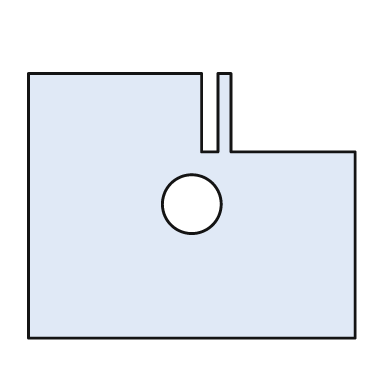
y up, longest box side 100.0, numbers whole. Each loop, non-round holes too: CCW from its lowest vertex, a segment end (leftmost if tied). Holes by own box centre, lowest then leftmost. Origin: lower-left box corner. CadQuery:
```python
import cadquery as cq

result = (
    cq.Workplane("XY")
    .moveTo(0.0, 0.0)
    .lineTo(100.0, 0.0)
    .lineTo(100.0, 57.0)
    .lineTo(62.0, 57.0)
    .lineTo(62.0, 81.0)
    .lineTo(58.0, 81.0)
    .lineTo(58.0, 57.0)
    .lineTo(53.0, 57.0)
    .lineTo(53.0, 81.0)
    .lineTo(0.0, 81.0)
    .close()
    .moveTo(50.0, 41.0)
    .circle(9.0)
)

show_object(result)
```